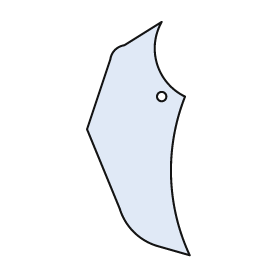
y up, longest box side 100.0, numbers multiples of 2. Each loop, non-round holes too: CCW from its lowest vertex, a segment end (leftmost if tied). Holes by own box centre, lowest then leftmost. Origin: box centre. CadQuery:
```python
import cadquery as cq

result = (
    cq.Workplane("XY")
    .moveTo(22.0, -50.0)
    .threePointArc((14.0, -16.0), (20.0, 18.0))
    .threePointArc((8.0, 32.0), (10.0, 50.0))
    .lineTo(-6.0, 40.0)
    .threePointArc((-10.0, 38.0), (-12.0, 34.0))
    .lineTo(-22.0, 4.0)
    .lineTo(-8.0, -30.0)
    .threePointArc((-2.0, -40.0), (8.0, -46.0))
    .close()
    .moveTo(10.0, 18.0)
    .circle(2.0)
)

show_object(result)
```